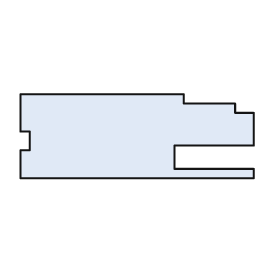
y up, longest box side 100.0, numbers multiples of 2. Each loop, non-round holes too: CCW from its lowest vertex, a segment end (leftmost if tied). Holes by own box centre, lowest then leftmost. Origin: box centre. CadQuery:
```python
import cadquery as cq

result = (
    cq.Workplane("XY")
    .moveTo(-50.0, -18.0)
    .lineTo(50.0, -18.0)
    .lineTo(50.0, -14.0)
    .lineTo(16.0, -14.0)
    .lineTo(16.0, -4.0)
    .lineTo(50.0, -4.0)
    .lineTo(50.0, 10.0)
    .lineTo(42.0, 10.0)
    .lineTo(42.0, 14.0)
    .lineTo(20.0, 14.0)
    .lineTo(20.0, 18.0)
    .lineTo(-50.0, 18.0)
    .lineTo(-50.0, 2.0)
    .lineTo(-46.0, 2.0)
    .lineTo(-46.0, -6.0)
    .lineTo(-50.0, -6.0)
    .close()
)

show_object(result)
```